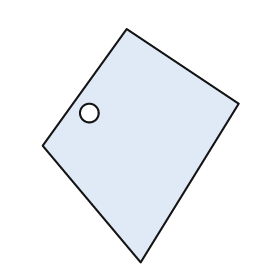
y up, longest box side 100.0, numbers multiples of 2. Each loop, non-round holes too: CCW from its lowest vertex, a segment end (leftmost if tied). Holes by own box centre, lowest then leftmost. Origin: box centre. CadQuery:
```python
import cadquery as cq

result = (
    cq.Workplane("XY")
    .moveTo(0.0, -50.0)
    .lineTo(42.0, 18.0)
    .lineTo(-6.0, 50.0)
    .lineTo(-42.0, 0.0)
    .close()
    .moveTo(-22.0, 14.0)
    .circle(4.0)
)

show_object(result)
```